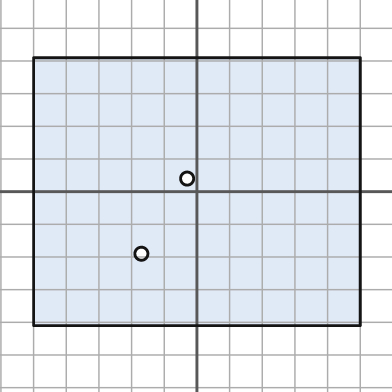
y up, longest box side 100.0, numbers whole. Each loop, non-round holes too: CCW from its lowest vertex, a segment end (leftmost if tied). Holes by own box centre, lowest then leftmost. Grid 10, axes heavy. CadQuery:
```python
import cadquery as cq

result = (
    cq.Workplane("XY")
    .moveTo(-50.0, -41.0)
    .lineTo(50.0, -41.0)
    .lineTo(50.0, 41.0)
    .lineTo(-50.0, 41.0)
    .close()
    .moveTo(-17.0, -19.0)
    .circle(2.0)
    .moveTo(-3.0, 4.0)
    .circle(2.0)
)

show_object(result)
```